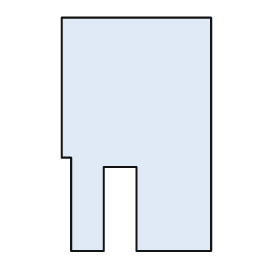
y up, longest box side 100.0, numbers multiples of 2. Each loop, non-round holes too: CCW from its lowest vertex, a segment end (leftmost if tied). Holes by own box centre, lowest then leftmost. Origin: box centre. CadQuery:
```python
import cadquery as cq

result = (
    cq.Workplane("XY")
    .moveTo(-28.0, -50.0)
    .lineTo(-14.0, -50.0)
    .lineTo(-14.0, -14.0)
    .lineTo(0.0, -14.0)
    .lineTo(0.0, -50.0)
    .lineTo(32.0, -50.0)
    .lineTo(32.0, 50.0)
    .lineTo(-32.0, 50.0)
    .lineTo(-32.0, -10.0)
    .lineTo(-28.0, -10.0)
    .close()
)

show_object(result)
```